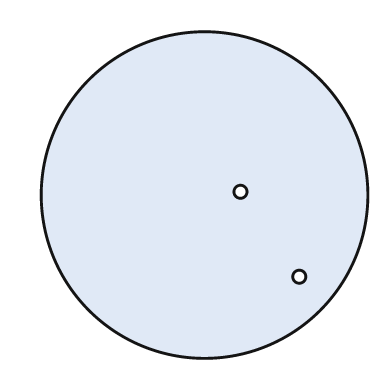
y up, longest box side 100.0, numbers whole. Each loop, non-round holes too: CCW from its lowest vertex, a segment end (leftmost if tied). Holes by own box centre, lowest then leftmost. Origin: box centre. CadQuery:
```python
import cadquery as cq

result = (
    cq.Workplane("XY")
    .moveTo(0.0, 0.0)
    .circle(50.0)
    .moveTo(29.0, -25.0)
    .circle(2.0)
    .moveTo(11.0, 1.0)
    .circle(2.0)
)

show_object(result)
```